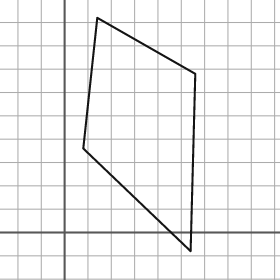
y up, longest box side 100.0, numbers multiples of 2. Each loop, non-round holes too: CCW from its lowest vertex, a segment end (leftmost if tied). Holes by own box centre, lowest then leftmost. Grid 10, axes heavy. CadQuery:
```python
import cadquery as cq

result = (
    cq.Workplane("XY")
    .moveTo(54.0, -8.0)
    .lineTo(56.0, 68.0)
    .lineTo(14.0, 92.0)
    .lineTo(8.0, 36.0)
    .close()
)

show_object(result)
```